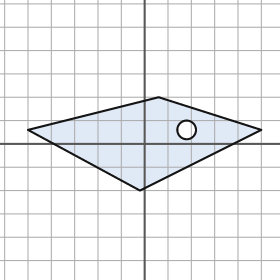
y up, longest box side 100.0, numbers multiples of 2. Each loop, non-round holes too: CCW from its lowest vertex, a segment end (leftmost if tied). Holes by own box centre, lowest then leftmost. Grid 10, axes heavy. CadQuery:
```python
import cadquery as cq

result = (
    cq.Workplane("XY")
    .moveTo(-2.0, -20.0)
    .lineTo(50.0, 6.0)
    .lineTo(6.0, 20.0)
    .lineTo(-50.0, 6.0)
    .close()
    .moveTo(18.0, 6.0)
    .circle(4.0)
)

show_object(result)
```